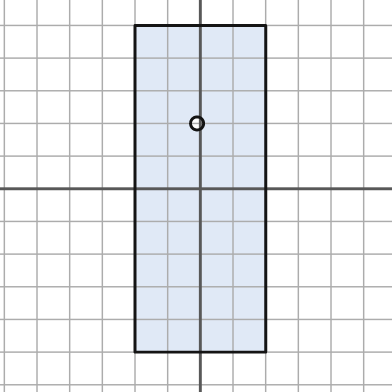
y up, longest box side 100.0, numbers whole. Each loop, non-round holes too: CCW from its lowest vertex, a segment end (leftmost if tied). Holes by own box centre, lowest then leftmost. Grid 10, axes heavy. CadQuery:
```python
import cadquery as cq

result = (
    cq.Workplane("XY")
    .moveTo(-20.0, -50.0)
    .lineTo(20.0, -50.0)
    .lineTo(20.0, 50.0)
    .lineTo(-20.0, 50.0)
    .close()
    .moveTo(-1.0, 20.0)
    .circle(2.0)
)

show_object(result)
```